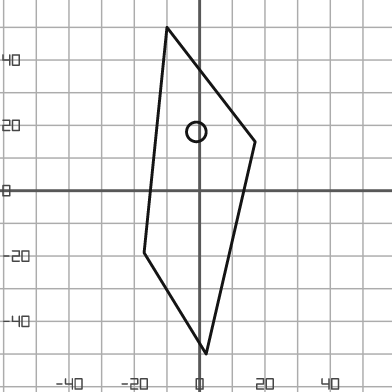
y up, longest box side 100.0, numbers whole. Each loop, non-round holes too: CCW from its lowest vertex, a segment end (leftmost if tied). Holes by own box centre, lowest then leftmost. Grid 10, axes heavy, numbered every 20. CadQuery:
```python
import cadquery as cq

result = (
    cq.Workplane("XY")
    .moveTo(2.0, -50.0)
    .lineTo(17.0, 15.0)
    .lineTo(-10.0, 50.0)
    .lineTo(-17.0, -19.0)
    .close()
    .moveTo(-1.0, 18.0)
    .circle(3.0)
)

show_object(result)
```